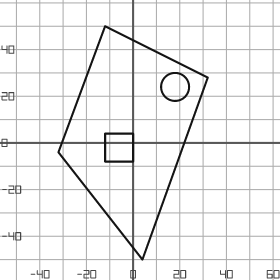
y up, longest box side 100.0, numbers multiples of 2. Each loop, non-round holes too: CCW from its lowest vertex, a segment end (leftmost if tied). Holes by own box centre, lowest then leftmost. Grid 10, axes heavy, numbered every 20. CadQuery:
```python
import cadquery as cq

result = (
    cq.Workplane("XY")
    .moveTo(4.0, -50.0)
    .lineTo(32.0, 28.0)
    .lineTo(-12.0, 50.0)
    .lineTo(-32.0, -4.0)
    .close()
    .moveTo(-12.0, -8.0)
    .lineTo(0.0, -8.0)
    .lineTo(0.0, 4.0)
    .lineTo(-12.0, 4.0)
    .close()
    .moveTo(18.0, 24.0)
    .circle(6.0)
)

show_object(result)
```